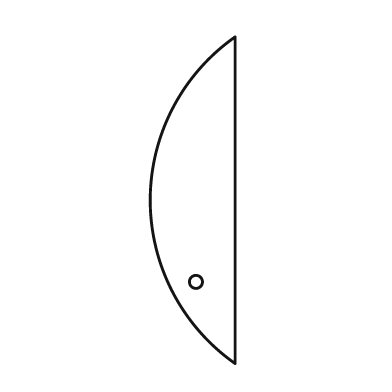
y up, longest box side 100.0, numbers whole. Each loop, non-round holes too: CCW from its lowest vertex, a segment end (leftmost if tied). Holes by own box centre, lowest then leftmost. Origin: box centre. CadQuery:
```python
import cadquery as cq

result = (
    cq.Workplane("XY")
    .moveTo(13.0, -50.0)
    .lineTo(13.0, 50.0)
    .threePointArc((-13.0, 0.0), (13.0, -50.0))
    .close()
    .moveTo(1.0, -25.0)
    .circle(2.0)
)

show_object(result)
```